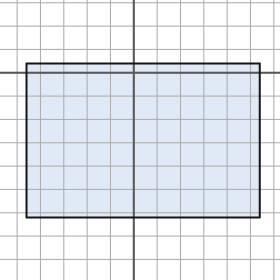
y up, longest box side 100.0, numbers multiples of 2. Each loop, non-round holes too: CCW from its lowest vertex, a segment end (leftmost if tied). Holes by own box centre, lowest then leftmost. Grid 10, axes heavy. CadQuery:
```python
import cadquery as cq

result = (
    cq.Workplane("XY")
    .moveTo(-46.0, -62.0)
    .lineTo(54.0, -62.0)
    .lineTo(54.0, 4.0)
    .lineTo(-46.0, 4.0)
    .close()
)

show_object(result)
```